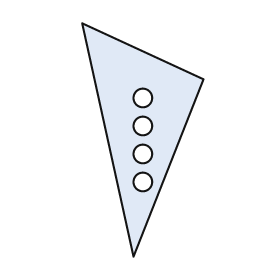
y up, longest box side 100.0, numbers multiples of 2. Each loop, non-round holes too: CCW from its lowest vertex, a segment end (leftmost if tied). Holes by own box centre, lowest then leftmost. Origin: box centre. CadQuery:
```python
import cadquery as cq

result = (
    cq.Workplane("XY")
    .moveTo(-4.0, -50.0)
    .lineTo(26.0, 26.0)
    .lineTo(-26.0, 50.0)
    .close()
    .moveTo(0.0, -18.0)
    .circle(4.0)
    .moveTo(0.0, -6.0)
    .circle(4.0)
    .moveTo(0.0, 6.0)
    .circle(4.0)
    .moveTo(0.0, 18.0)
    .circle(4.0)
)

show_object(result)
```